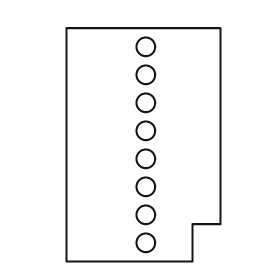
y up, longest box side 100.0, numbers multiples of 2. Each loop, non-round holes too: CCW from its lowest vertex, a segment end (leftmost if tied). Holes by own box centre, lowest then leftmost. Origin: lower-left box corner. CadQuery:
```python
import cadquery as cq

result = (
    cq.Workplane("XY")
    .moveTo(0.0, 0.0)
    .lineTo(54.0, 0.0)
    .lineTo(54.0, 16.0)
    .lineTo(66.0, 16.0)
    .lineTo(66.0, 100.0)
    .lineTo(0.0, 100.0)
    .close()
    .moveTo(34.0, 8.0)
    .circle(4.0)
    .moveTo(34.0, 20.0)
    .circle(4.0)
    .moveTo(34.0, 32.0)
    .circle(4.0)
    .moveTo(34.0, 44.0)
    .circle(4.0)
    .moveTo(34.0, 56.0)
    .circle(4.0)
    .moveTo(34.0, 68.0)
    .circle(4.0)
    .moveTo(34.0, 80.0)
    .circle(4.0)
    .moveTo(34.0, 92.0)
    .circle(4.0)
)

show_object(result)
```